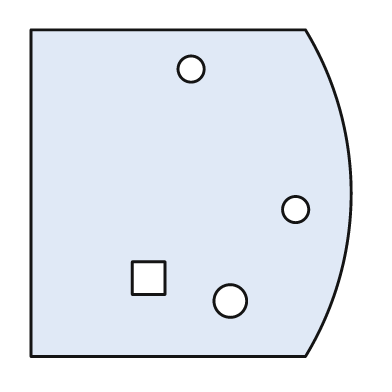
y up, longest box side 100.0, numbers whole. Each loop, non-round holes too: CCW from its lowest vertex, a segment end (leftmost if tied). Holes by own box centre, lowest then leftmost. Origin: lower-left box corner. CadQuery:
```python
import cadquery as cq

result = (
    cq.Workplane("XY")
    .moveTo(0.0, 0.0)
    .lineTo(84.0, 0.0)
    .threePointArc((98.0, 50.0), (84.0, 100.0))
    .lineTo(0.0, 100.0)
    .close()
    .moveTo(61.0, 17.0)
    .circle(5.0)
    .moveTo(31.0, 19.0)
    .lineTo(41.0, 19.0)
    .lineTo(41.0, 29.0)
    .lineTo(31.0, 29.0)
    .close()
    .moveTo(81.0, 45.0)
    .circle(4.0)
    .moveTo(49.0, 88.0)
    .circle(4.0)
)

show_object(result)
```